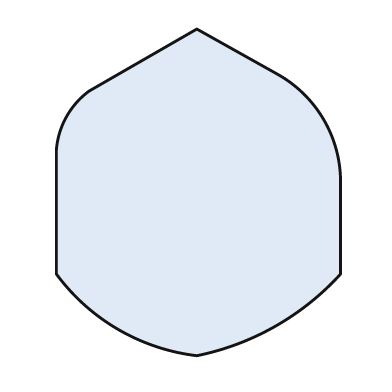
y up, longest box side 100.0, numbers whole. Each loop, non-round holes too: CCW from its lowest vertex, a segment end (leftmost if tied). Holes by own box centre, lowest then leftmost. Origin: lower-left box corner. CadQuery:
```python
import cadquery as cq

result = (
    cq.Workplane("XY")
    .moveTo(43.0, 0.0)
    .threePointArc((67.0, 9.0), (87.0, 25.0))
    .lineTo(87.0, 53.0)
    .threePointArc((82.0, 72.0), (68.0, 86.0))
    .lineTo(43.0, 100.0)
    .lineTo(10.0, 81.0)
    .threePointArc((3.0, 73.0), (0.0, 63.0))
    .lineTo(0.0, 25.0)
    .threePointArc((19.0, 8.0), (43.0, 0.0))
    .close()
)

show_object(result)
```